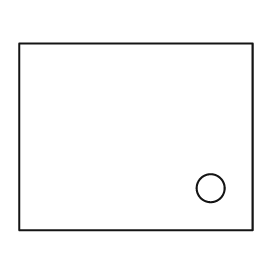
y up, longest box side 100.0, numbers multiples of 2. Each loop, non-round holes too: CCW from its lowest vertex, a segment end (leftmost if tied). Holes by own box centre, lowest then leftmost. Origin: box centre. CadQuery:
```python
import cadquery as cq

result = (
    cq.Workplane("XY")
    .moveTo(-50.0, -40.0)
    .lineTo(50.0, -40.0)
    .lineTo(50.0, 40.0)
    .lineTo(-50.0, 40.0)
    .close()
    .moveTo(32.0, -22.0)
    .circle(6.0)
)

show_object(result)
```